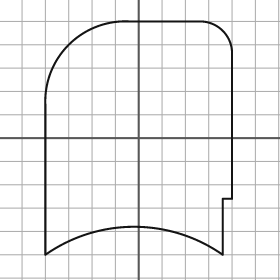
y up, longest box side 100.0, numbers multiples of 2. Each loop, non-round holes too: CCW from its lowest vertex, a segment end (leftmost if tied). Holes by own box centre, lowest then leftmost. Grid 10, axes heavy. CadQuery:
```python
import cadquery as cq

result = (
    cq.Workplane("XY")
    .moveTo(-40.0, -50.0)
    .threePointArc((-2.0, -38.0), (36.0, -50.0))
    .lineTo(36.0, -26.0)
    .lineTo(40.0, -26.0)
    .lineTo(40.0, 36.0)
    .threePointArc((36.0, 46.0), (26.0, 50.0))
    .lineTo(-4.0, 50.0)
    .threePointArc((-30.0, 40.0), (-40.0, 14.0))
    .close()
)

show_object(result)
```